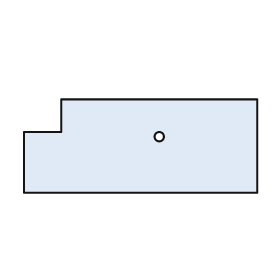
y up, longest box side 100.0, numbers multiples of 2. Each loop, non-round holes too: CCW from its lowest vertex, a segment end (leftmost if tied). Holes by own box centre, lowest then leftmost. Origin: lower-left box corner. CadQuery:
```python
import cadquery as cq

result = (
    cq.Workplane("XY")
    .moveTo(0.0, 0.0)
    .lineTo(100.0, 0.0)
    .lineTo(100.0, 40.0)
    .lineTo(16.0, 40.0)
    .lineTo(16.0, 26.0)
    .lineTo(0.0, 26.0)
    .close()
    .moveTo(58.0, 24.0)
    .circle(2.0)
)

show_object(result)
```